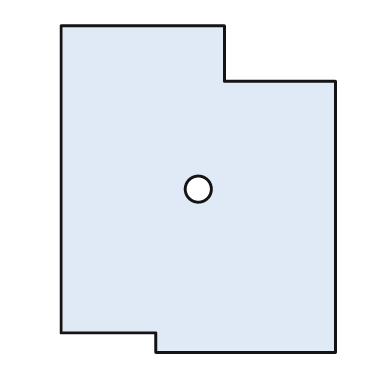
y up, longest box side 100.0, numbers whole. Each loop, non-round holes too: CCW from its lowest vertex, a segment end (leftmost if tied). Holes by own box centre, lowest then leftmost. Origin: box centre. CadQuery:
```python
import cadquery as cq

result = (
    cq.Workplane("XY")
    .moveTo(-13.0, -50.0)
    .lineTo(42.0, -50.0)
    .lineTo(42.0, 33.0)
    .lineTo(8.0, 33.0)
    .lineTo(8.0, 50.0)
    .lineTo(-42.0, 50.0)
    .lineTo(-42.0, -44.0)
    .lineTo(-13.0, -44.0)
    .close()
    .moveTo(0.0, 0.0)
    .circle(4.0)
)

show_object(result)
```